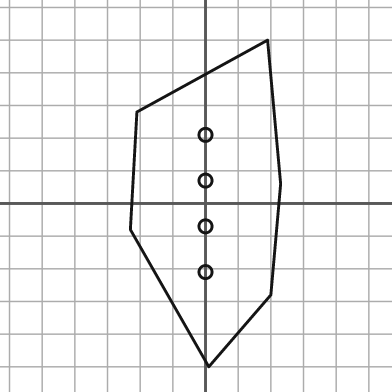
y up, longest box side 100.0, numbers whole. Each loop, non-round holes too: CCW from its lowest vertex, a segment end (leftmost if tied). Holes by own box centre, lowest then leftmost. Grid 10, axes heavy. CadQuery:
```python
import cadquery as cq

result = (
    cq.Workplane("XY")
    .moveTo(1.0, -50.0)
    .lineTo(20.0, -28.0)
    .lineTo(23.0, 6.0)
    .lineTo(19.0, 50.0)
    .lineTo(-21.0, 28.0)
    .lineTo(-23.0, -8.0)
    .close()
    .moveTo(0.0, -21.0)
    .circle(2.0)
    .moveTo(0.0, -7.0)
    .circle(2.0)
    .moveTo(0.0, 7.0)
    .circle(2.0)
    .moveTo(0.0, 21.0)
    .circle(2.0)
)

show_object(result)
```